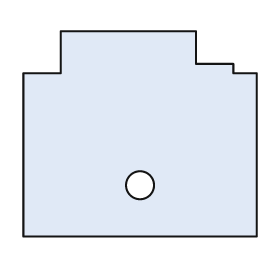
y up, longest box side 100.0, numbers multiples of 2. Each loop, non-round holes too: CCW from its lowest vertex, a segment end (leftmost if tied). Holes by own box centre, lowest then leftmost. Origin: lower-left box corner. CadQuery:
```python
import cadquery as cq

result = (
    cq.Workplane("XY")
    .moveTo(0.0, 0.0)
    .lineTo(100.0, 0.0)
    .lineTo(100.0, 70.0)
    .lineTo(90.0, 70.0)
    .lineTo(90.0, 74.0)
    .lineTo(74.0, 74.0)
    .lineTo(74.0, 88.0)
    .lineTo(16.0, 88.0)
    .lineTo(16.0, 70.0)
    .lineTo(0.0, 70.0)
    .close()
    .moveTo(50.0, 22.0)
    .circle(6.0)
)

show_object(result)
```